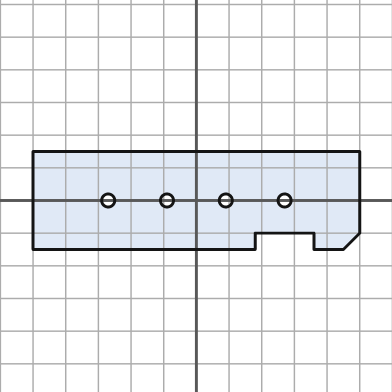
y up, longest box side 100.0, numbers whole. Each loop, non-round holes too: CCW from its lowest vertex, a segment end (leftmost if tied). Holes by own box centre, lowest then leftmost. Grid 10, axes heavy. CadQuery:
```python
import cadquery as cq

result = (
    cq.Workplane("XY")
    .moveTo(-50.0, -15.0)
    .lineTo(18.0, -15.0)
    .lineTo(18.0, -10.0)
    .lineTo(36.0, -10.0)
    .lineTo(36.0, -15.0)
    .lineTo(45.0, -15.0)
    .lineTo(50.0, -10.0)
    .lineTo(50.0, 15.0)
    .lineTo(-50.0, 15.0)
    .close()
    .moveTo(-27.0, 0.0)
    .circle(2.0)
    .moveTo(-9.0, 0.0)
    .circle(2.0)
    .moveTo(9.0, 0.0)
    .circle(2.0)
    .moveTo(27.0, 0.0)
    .circle(2.0)
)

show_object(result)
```